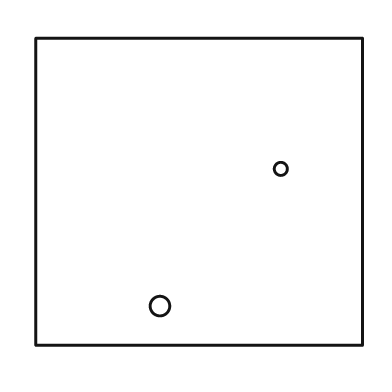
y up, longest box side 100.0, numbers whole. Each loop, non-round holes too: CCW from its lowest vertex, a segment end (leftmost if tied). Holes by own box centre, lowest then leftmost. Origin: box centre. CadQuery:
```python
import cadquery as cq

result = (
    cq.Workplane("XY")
    .moveTo(-50.0, -47.0)
    .lineTo(50.0, -47.0)
    .lineTo(50.0, 47.0)
    .lineTo(-50.0, 47.0)
    .close()
    .moveTo(-12.0, -35.0)
    .circle(3.0)
    .moveTo(25.0, 7.0)
    .circle(2.0)
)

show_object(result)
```